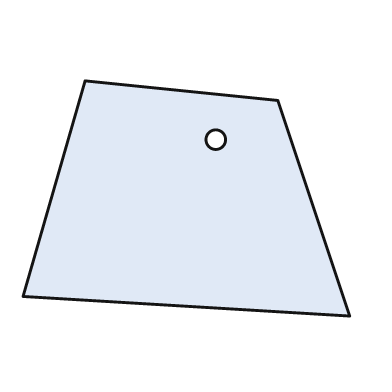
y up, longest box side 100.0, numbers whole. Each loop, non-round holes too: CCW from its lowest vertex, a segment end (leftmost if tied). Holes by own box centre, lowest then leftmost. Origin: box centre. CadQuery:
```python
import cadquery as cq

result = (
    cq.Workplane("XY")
    .moveTo(50.0, -36.0)
    .lineTo(28.0, 30.0)
    .lineTo(-31.0, 36.0)
    .lineTo(-50.0, -30.0)
    .close()
    .moveTo(9.0, 18.0)
    .circle(3.0)
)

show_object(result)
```